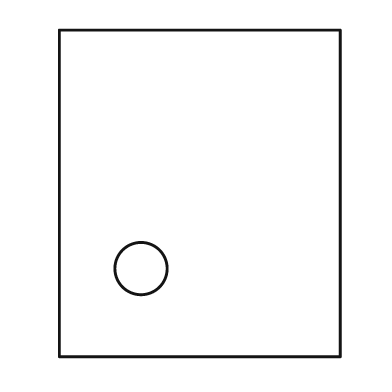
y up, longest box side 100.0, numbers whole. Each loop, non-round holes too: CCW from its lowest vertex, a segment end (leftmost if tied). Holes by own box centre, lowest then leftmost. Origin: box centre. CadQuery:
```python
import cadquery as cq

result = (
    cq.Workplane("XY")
    .moveTo(-43.0, -50.0)
    .lineTo(43.0, -50.0)
    .lineTo(43.0, 50.0)
    .lineTo(-43.0, 50.0)
    .close()
    .moveTo(-18.0, -23.0)
    .circle(8.0)
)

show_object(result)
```